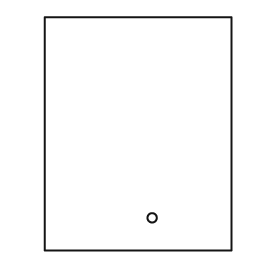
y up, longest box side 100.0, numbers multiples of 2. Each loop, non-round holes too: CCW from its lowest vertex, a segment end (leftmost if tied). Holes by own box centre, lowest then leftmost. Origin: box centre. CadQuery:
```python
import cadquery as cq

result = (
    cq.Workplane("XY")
    .moveTo(-40.0, -50.0)
    .lineTo(40.0, -50.0)
    .lineTo(40.0, 50.0)
    .lineTo(-40.0, 50.0)
    .close()
    .moveTo(6.0, -36.0)
    .circle(2.0)
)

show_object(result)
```